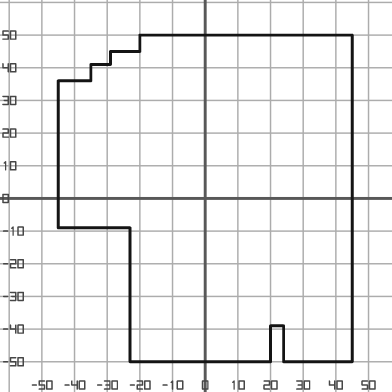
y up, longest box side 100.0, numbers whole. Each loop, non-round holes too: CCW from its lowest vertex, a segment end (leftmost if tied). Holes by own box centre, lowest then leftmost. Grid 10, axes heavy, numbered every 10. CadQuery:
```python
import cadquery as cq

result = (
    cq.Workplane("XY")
    .moveTo(-23.0, -50.0)
    .lineTo(20.0, -50.0)
    .lineTo(20.0, -39.0)
    .lineTo(24.0, -39.0)
    .lineTo(24.0, -50.0)
    .lineTo(45.0, -50.0)
    .lineTo(45.0, 50.0)
    .lineTo(-20.0, 50.0)
    .lineTo(-20.0, 45.0)
    .lineTo(-29.0, 45.0)
    .lineTo(-29.0, 41.0)
    .lineTo(-35.0, 41.0)
    .lineTo(-35.0, 36.0)
    .lineTo(-45.0, 36.0)
    .lineTo(-45.0, -9.0)
    .lineTo(-23.0, -9.0)
    .close()
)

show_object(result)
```